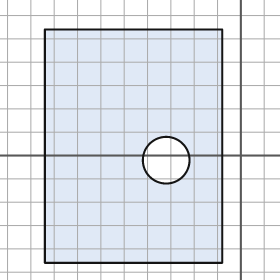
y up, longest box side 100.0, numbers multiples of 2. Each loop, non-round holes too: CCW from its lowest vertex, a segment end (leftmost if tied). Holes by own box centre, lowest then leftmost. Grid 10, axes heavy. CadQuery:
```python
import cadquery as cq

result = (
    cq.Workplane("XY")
    .moveTo(-84.0, -46.0)
    .lineTo(-8.0, -46.0)
    .lineTo(-8.0, 54.0)
    .lineTo(-84.0, 54.0)
    .close()
    .moveTo(-32.0, -2.0)
    .circle(10.0)
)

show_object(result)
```